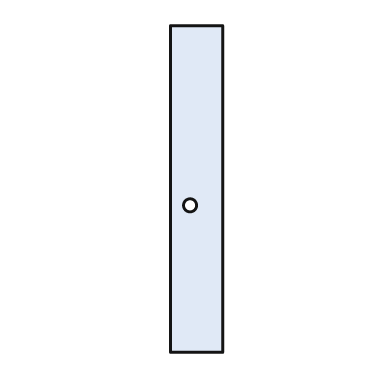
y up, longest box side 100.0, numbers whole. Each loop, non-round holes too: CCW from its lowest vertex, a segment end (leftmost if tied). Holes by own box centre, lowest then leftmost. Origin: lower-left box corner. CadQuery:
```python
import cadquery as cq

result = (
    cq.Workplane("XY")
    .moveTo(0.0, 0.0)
    .lineTo(16.0, 0.0)
    .lineTo(16.0, 100.0)
    .lineTo(0.0, 100.0)
    .close()
    .moveTo(6.0, 45.0)
    .circle(2.0)
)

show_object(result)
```